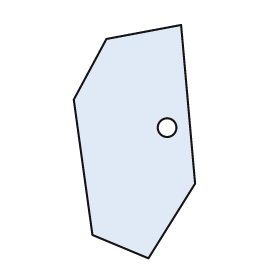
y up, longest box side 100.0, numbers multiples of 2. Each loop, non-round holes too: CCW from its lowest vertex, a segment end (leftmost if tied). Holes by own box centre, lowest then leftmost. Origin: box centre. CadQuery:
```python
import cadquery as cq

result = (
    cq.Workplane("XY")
    .moveTo(6.0, -50.0)
    .lineTo(26.0, -18.0)
    .lineTo(20.0, 50.0)
    .lineTo(-12.0, 44.0)
    .lineTo(-26.0, 18.0)
    .lineTo(-18.0, -40.0)
    .close()
    .moveTo(14.0, 6.0)
    .circle(4.0)
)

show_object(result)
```